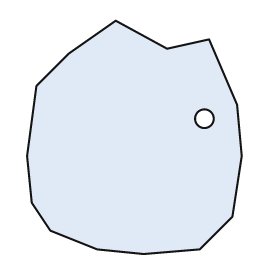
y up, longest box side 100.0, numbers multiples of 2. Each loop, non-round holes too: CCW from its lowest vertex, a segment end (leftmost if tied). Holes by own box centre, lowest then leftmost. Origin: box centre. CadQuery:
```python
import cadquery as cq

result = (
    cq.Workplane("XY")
    .moveTo(4.0, -50.0)
    .lineTo(28.0, -48.0)
    .lineTo(42.0, -34.0)
    .lineTo(46.0, -8.0)
    .lineTo(44.0, 14.0)
    .lineTo(32.0, 42.0)
    .lineTo(14.0, 38.0)
    .lineTo(-8.0, 50.0)
    .lineTo(-28.0, 36.0)
    .lineTo(-42.0, 22.0)
    .lineTo(-46.0, -8.0)
    .lineTo(-44.0, -28.0)
    .lineTo(-36.0, -40.0)
    .lineTo(-16.0, -48.0)
    .close()
    .moveTo(30.0, 8.0)
    .circle(4.0)
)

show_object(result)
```